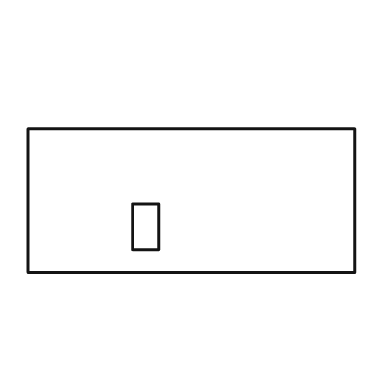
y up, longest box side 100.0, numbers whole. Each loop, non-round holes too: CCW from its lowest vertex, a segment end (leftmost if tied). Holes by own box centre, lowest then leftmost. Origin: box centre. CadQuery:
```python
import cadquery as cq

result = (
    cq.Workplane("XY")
    .moveTo(-50.0, -22.0)
    .lineTo(50.0, -22.0)
    .lineTo(50.0, 22.0)
    .lineTo(-50.0, 22.0)
    .close()
    .moveTo(-18.0, -15.0)
    .lineTo(-10.0, -15.0)
    .lineTo(-10.0, -1.0)
    .lineTo(-18.0, -1.0)
    .close()
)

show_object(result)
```